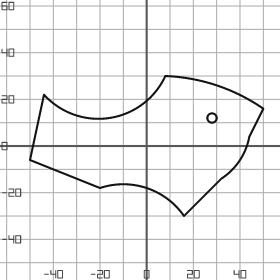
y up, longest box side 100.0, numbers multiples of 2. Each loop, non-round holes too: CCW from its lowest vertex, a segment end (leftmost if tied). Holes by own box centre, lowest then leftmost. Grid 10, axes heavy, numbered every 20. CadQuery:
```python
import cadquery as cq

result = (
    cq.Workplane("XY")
    .moveTo(16.0, -30.0)
    .lineTo(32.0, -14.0)
    .threePointArc((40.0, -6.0), (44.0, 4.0))
    .lineTo(50.0, 16.0)
    .threePointArc((30.0, 26.0), (8.0, 30.0))
    .threePointArc((-16.0, 12.0), (-44.0, 22.0))
    .lineTo(-50.0, -6.0)
    .lineTo(-20.0, -18.0)
    .threePointArc((0.0, -18.0), (16.0, -30.0))
    .close()
    .moveTo(28.0, 12.0)
    .circle(2.0)
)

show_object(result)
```